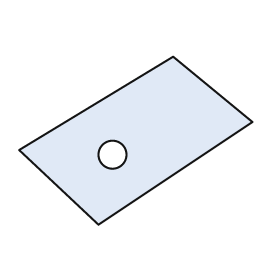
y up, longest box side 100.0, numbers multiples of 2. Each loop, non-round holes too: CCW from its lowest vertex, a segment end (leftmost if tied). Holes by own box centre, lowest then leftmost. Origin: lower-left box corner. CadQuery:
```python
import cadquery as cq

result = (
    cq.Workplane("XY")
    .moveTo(34.0, 0.0)
    .lineTo(100.0, 44.0)
    .lineTo(66.0, 72.0)
    .lineTo(0.0, 32.0)
    .close()
    .moveTo(40.0, 30.0)
    .circle(6.0)
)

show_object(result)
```